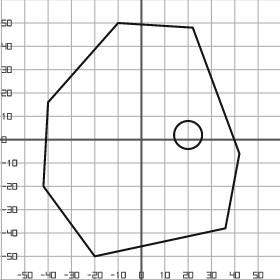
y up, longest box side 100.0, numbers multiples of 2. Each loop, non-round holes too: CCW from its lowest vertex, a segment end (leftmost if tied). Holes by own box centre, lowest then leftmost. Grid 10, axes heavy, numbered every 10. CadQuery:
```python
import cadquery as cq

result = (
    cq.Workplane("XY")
    .moveTo(-20.0, -50.0)
    .lineTo(36.0, -38.0)
    .lineTo(42.0, -6.0)
    .lineTo(22.0, 48.0)
    .lineTo(-10.0, 50.0)
    .lineTo(-40.0, 16.0)
    .lineTo(-42.0, -20.0)
    .close()
    .moveTo(20.0, 2.0)
    .circle(6.0)
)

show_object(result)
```